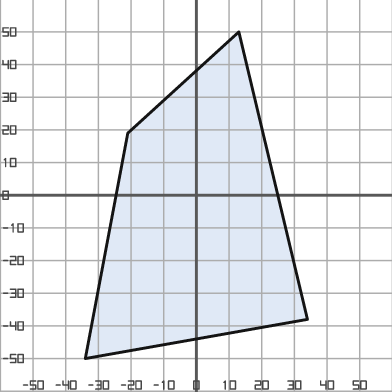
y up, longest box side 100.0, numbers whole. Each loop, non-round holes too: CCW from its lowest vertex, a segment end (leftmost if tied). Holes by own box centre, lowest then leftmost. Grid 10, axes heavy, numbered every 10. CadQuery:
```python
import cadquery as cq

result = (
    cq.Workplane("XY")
    .moveTo(-34.0, -50.0)
    .lineTo(34.0, -38.0)
    .lineTo(13.0, 50.0)
    .lineTo(-21.0, 19.0)
    .close()
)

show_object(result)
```